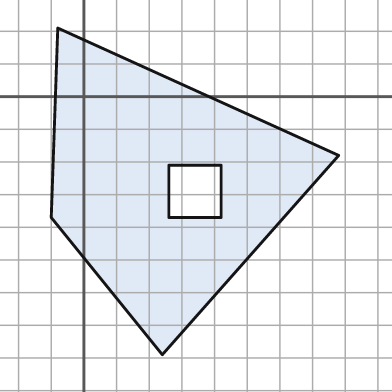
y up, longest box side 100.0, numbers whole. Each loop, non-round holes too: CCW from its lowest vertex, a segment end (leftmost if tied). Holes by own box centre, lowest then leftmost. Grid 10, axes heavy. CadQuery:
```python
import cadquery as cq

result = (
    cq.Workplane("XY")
    .moveTo(24.0, -79.0)
    .lineTo(78.0, -18.0)
    .lineTo(-8.0, 21.0)
    .lineTo(-10.0, -37.0)
    .close()
    .moveTo(26.0, -37.0)
    .lineTo(42.0, -37.0)
    .lineTo(42.0, -21.0)
    .lineTo(26.0, -21.0)
    .close()
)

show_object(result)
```